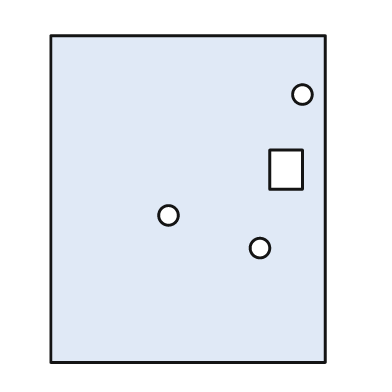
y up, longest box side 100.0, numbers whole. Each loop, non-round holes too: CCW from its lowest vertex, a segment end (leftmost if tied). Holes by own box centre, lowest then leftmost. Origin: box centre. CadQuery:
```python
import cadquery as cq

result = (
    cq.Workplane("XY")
    .moveTo(-42.0, -50.0)
    .lineTo(42.0, -50.0)
    .lineTo(42.0, 50.0)
    .lineTo(-42.0, 50.0)
    .close()
    .moveTo(22.0, -15.0)
    .circle(3.0)
    .moveTo(-6.0, -5.0)
    .circle(3.0)
    .moveTo(25.0, 3.0)
    .lineTo(35.0, 3.0)
    .lineTo(35.0, 15.0)
    .lineTo(25.0, 15.0)
    .close()
    .moveTo(35.0, 32.0)
    .circle(3.0)
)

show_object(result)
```